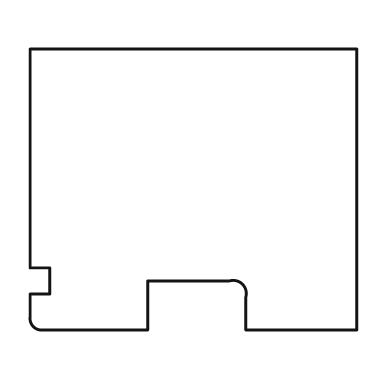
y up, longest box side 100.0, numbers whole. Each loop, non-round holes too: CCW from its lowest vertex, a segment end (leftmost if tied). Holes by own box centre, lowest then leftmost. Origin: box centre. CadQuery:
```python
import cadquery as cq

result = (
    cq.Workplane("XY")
    .moveTo(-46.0, -43.0)
    .lineTo(-14.0, -43.0)
    .lineTo(-14.0, -28.0)
    .lineTo(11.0, -28.0)
    .threePointArc((15.0, -29.0), (16.0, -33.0))
    .lineTo(16.0, -43.0)
    .lineTo(50.0, -43.0)
    .lineTo(50.0, 43.0)
    .lineTo(-50.0, 43.0)
    .lineTo(-50.0, -24.0)
    .lineTo(-44.0, -24.0)
    .lineTo(-44.0, -32.0)
    .lineTo(-50.0, -32.0)
    .lineTo(-50.0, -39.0)
    .threePointArc((-49.0, -42.0), (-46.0, -43.0))
    .close()
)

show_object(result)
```